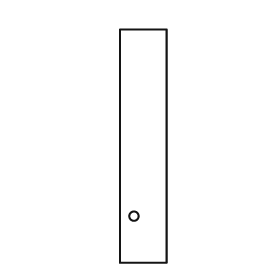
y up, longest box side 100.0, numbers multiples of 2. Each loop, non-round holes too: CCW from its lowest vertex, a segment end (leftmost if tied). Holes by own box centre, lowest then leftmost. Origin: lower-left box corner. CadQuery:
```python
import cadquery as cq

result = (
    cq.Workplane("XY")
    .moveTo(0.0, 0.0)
    .lineTo(20.0, 0.0)
    .lineTo(20.0, 100.0)
    .lineTo(0.0, 100.0)
    .close()
    .moveTo(6.0, 20.0)
    .circle(2.0)
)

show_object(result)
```